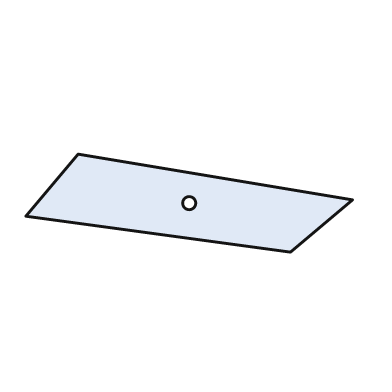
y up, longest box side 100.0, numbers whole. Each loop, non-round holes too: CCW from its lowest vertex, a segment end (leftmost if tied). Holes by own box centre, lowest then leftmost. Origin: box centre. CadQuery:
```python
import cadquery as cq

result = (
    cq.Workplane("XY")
    .moveTo(31.0, -15.0)
    .lineTo(50.0, 1.0)
    .lineTo(-34.0, 15.0)
    .lineTo(-50.0, -4.0)
    .close()
    .moveTo(0.0, 0.0)
    .circle(2.0)
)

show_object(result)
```